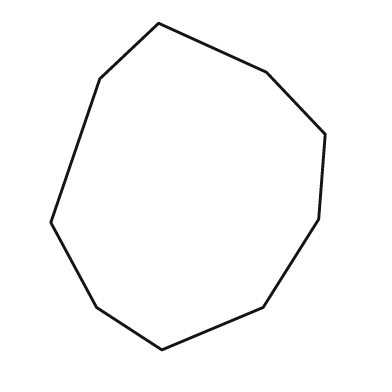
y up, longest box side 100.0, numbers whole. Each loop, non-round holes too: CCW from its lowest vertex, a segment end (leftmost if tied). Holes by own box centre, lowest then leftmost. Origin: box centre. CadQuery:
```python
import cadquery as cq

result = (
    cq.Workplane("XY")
    .moveTo(-8.0, -50.0)
    .lineTo(23.0, -37.0)
    .lineTo(40.0, -10.0)
    .lineTo(42.0, 16.0)
    .lineTo(24.0, 35.0)
    .lineTo(-9.0, 50.0)
    .lineTo(-27.0, 33.0)
    .lineTo(-42.0, -11.0)
    .lineTo(-28.0, -37.0)
    .close()
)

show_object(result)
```